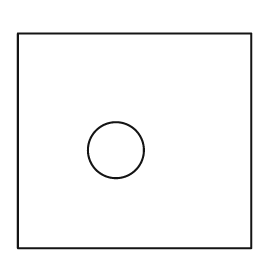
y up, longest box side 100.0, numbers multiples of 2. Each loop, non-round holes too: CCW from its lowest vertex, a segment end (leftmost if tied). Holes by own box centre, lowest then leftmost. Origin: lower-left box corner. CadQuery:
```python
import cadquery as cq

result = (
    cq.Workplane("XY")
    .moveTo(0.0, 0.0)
    .lineTo(100.0, 0.0)
    .lineTo(100.0, 92.0)
    .lineTo(0.0, 92.0)
    .close()
    .moveTo(42.0, 42.0)
    .circle(12.0)
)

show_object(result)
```